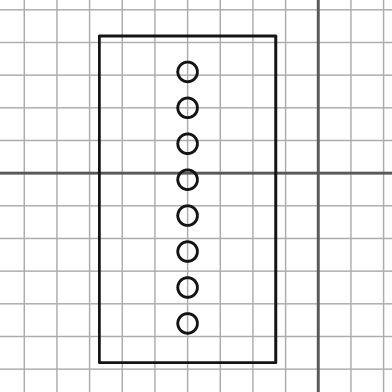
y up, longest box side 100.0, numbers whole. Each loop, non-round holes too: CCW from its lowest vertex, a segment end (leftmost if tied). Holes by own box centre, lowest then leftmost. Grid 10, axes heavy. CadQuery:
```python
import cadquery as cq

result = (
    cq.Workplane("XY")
    .moveTo(-67.0, -58.0)
    .lineTo(-13.0, -58.0)
    .lineTo(-13.0, 42.0)
    .lineTo(-67.0, 42.0)
    .close()
    .moveTo(-40.0, -46.0)
    .circle(3.0)
    .moveTo(-40.0, -35.0)
    .circle(3.0)
    .moveTo(-40.0, -24.0)
    .circle(3.0)
    .moveTo(-40.0, -13.0)
    .circle(3.0)
    .moveTo(-40.0, -2.0)
    .circle(3.0)
    .moveTo(-40.0, 9.0)
    .circle(3.0)
    .moveTo(-40.0, 20.0)
    .circle(3.0)
    .moveTo(-40.0, 31.0)
    .circle(3.0)
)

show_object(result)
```